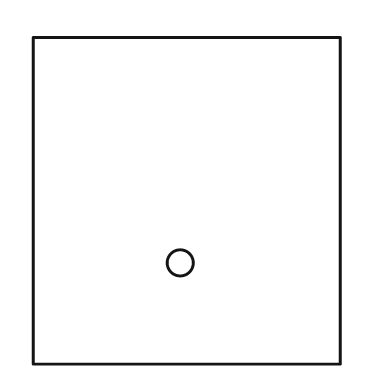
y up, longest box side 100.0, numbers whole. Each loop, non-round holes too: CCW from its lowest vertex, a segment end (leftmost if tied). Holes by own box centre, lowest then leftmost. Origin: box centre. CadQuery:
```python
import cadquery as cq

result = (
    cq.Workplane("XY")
    .moveTo(-47.0, -50.0)
    .lineTo(47.0, -50.0)
    .lineTo(47.0, 50.0)
    .lineTo(-47.0, 50.0)
    .close()
    .moveTo(-2.0, -19.0)
    .circle(4.0)
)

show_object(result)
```